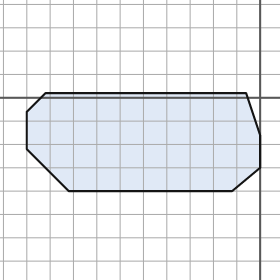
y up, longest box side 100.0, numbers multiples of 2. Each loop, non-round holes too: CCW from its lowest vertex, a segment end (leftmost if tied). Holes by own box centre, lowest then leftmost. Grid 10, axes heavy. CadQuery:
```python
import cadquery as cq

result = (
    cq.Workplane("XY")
    .moveTo(-82.0, -40.0)
    .lineTo(-12.0, -40.0)
    .lineTo(0.0, -30.0)
    .lineTo(0.0, -16.0)
    .lineTo(-6.0, 2.0)
    .lineTo(-92.0, 2.0)
    .lineTo(-100.0, -6.0)
    .lineTo(-100.0, -22.0)
    .close()
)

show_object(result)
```